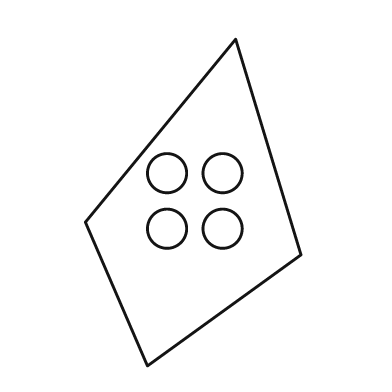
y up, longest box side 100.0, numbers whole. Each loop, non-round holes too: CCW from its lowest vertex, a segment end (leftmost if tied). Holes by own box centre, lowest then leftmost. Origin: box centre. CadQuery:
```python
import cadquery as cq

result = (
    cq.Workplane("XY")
    .moveTo(-14.0, -50.0)
    .lineTo(33.0, -16.0)
    .lineTo(13.0, 50.0)
    .lineTo(-33.0, -6.0)
    .close()
    .moveTo(-8.0, -8.0)
    .circle(6.0)
    .moveTo(9.0, -8.0)
    .circle(6.0)
    .moveTo(-8.0, 9.0)
    .circle(6.0)
    .moveTo(9.0, 9.0)
    .circle(6.0)
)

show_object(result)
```